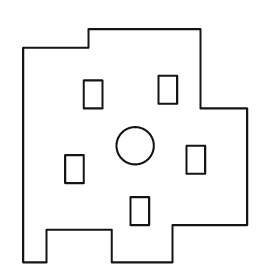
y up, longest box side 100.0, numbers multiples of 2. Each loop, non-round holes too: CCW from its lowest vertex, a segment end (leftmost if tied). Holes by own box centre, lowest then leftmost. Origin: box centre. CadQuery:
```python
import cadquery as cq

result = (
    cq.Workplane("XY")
    .moveTo(-48.0, -50.0)
    .lineTo(-38.0, -50.0)
    .lineTo(-38.0, -36.0)
    .lineTo(-10.0, -36.0)
    .lineTo(-10.0, -50.0)
    .lineTo(16.0, -50.0)
    .lineTo(16.0, -34.0)
    .lineTo(48.0, -34.0)
    .lineTo(48.0, 16.0)
    .lineTo(28.0, 16.0)
    .lineTo(28.0, 50.0)
    .lineTo(-20.0, 50.0)
    .lineTo(-20.0, 42.0)
    .lineTo(-48.0, 42.0)
    .close()
    .moveTo(-2.0, -34.0)
    .lineTo(6.0, -34.0)
    .lineTo(6.0, -22.0)
    .lineTo(-2.0, -22.0)
    .close()
    .moveTo(-30.0, -16.0)
    .lineTo(-22.0, -16.0)
    .lineTo(-22.0, -4.0)
    .lineTo(-30.0, -4.0)
    .close()
    .moveTo(22.0, -12.0)
    .lineTo(30.0, -12.0)
    .lineTo(30.0, 0.0)
    .lineTo(22.0, 0.0)
    .close()
    .moveTo(0.0, 0.0)
    .circle(8.0)
    .moveTo(-22.0, 16.0)
    .lineTo(-14.0, 16.0)
    .lineTo(-14.0, 28.0)
    .lineTo(-22.0, 28.0)
    .close()
    .moveTo(10.0, 18.0)
    .lineTo(18.0, 18.0)
    .lineTo(18.0, 30.0)
    .lineTo(10.0, 30.0)
    .close()
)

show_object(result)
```